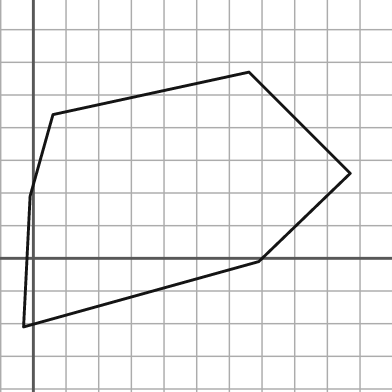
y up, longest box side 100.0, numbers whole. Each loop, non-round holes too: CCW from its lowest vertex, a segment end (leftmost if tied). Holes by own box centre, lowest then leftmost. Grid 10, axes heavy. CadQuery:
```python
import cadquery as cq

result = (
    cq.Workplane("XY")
    .moveTo(-3.0, -21.0)
    .lineTo(69.0, -1.0)
    .lineTo(97.0, 26.0)
    .lineTo(66.0, 57.0)
    .lineTo(6.0, 44.0)
    .lineTo(-1.0, 19.0)
    .close()
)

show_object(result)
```